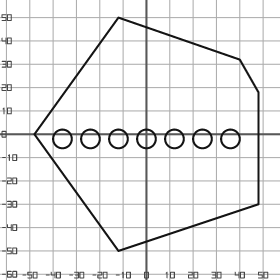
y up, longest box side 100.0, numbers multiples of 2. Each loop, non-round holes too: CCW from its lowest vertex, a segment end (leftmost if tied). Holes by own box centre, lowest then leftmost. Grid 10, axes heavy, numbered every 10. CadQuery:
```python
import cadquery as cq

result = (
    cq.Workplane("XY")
    .moveTo(-12.0, -50.0)
    .lineTo(48.0, -30.0)
    .lineTo(48.0, 18.0)
    .lineTo(40.0, 32.0)
    .lineTo(-12.0, 50.0)
    .lineTo(-48.0, 0.0)
    .close()
    .moveTo(-36.0, -2.0)
    .circle(4.0)
    .moveTo(-24.0, -2.0)
    .circle(4.0)
    .moveTo(-12.0, -2.0)
    .circle(4.0)
    .moveTo(0.0, -2.0)
    .circle(4.0)
    .moveTo(12.0, -2.0)
    .circle(4.0)
    .moveTo(24.0, -2.0)
    .circle(4.0)
    .moveTo(36.0, -2.0)
    .circle(4.0)
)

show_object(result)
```